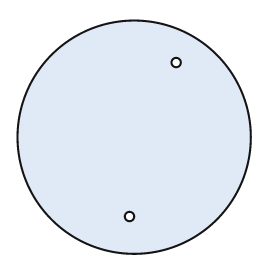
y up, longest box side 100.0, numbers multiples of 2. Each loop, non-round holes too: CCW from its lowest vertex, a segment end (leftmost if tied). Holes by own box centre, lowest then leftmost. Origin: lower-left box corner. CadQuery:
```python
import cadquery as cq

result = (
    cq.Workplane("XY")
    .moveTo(50.0, 50.0)
    .circle(50.0)
    .moveTo(48.0, 16.0)
    .circle(2.0)
    .moveTo(68.0, 82.0)
    .circle(2.0)
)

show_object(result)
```